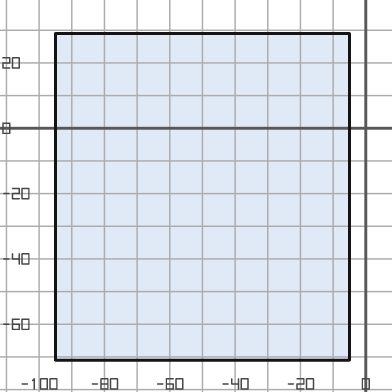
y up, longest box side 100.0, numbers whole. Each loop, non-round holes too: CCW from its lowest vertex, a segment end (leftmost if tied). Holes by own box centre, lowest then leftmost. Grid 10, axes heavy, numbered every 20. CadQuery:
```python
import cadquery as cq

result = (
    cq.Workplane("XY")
    .moveTo(-95.0, -71.0)
    .lineTo(-5.0, -71.0)
    .lineTo(-5.0, 29.0)
    .lineTo(-95.0, 29.0)
    .close()
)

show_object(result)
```